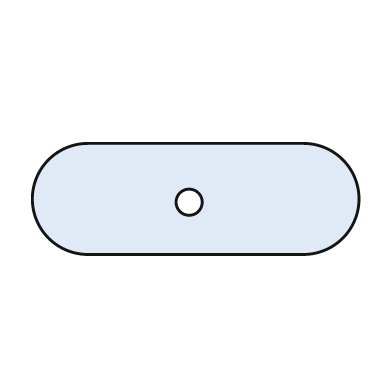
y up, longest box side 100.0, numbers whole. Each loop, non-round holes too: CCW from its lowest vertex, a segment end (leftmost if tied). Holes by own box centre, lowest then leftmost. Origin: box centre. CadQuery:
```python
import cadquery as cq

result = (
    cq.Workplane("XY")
    .moveTo(-33.0, -17.0)
    .lineTo(33.0, -17.0)
    .threePointArc((50.0, 0.0), (33.0, 17.0))
    .lineTo(-33.0, 17.0)
    .threePointArc((-50.0, 0.0), (-33.0, -17.0))
    .close()
    .moveTo(-2.0, -1.0)
    .circle(4.0)
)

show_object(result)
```